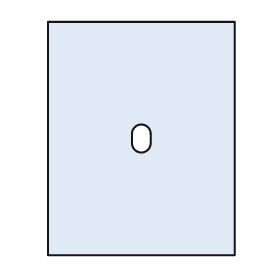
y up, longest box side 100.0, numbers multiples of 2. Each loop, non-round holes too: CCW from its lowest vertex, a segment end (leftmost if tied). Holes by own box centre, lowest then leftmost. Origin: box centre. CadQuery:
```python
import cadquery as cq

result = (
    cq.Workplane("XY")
    .moveTo(-40.0, -50.0)
    .lineTo(40.0, -50.0)
    .lineTo(40.0, 50.0)
    .lineTo(-40.0, 50.0)
    .close()
    .moveTo(-4.0, -2.0)
    .threePointArc((0.0, -6.0), (4.0, -2.0))
    .lineTo(4.0, 2.0)
    .threePointArc((0.0, 6.0), (-4.0, 2.0))
    .close()
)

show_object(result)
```